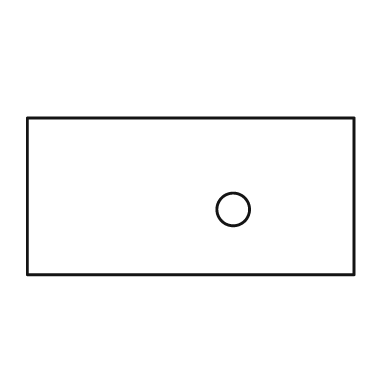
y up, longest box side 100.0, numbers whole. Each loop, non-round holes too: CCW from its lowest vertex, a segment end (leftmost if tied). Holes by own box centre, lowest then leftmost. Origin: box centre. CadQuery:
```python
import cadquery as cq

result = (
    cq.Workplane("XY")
    .moveTo(-50.0, -24.0)
    .lineTo(50.0, -24.0)
    .lineTo(50.0, 24.0)
    .lineTo(-50.0, 24.0)
    .close()
    .moveTo(13.0, -4.0)
    .circle(5.0)
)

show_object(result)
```